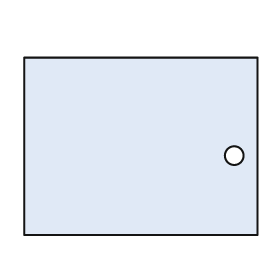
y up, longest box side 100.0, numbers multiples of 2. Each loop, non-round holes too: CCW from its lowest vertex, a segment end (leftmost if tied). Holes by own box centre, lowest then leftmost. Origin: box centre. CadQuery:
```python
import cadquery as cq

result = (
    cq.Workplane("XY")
    .moveTo(-50.0, -38.0)
    .lineTo(50.0, -38.0)
    .lineTo(50.0, 38.0)
    .lineTo(-50.0, 38.0)
    .close()
    .moveTo(40.0, -4.0)
    .circle(4.0)
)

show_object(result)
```